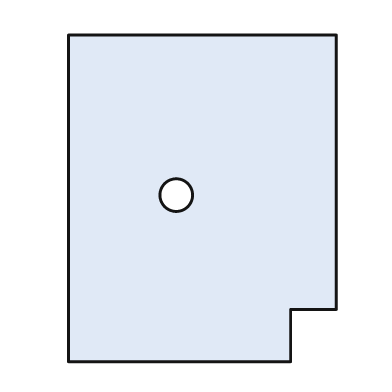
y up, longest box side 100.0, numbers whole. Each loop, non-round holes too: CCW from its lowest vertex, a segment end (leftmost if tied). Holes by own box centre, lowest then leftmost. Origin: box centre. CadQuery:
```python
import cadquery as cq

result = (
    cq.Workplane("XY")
    .moveTo(-41.0, -50.0)
    .lineTo(27.0, -50.0)
    .lineTo(27.0, -34.0)
    .lineTo(41.0, -34.0)
    .lineTo(41.0, 50.0)
    .lineTo(-41.0, 50.0)
    .close()
    .moveTo(-8.0, 1.0)
    .circle(5.0)
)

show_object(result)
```